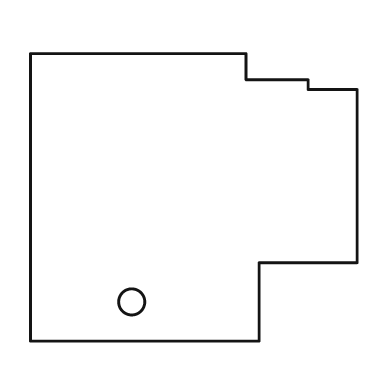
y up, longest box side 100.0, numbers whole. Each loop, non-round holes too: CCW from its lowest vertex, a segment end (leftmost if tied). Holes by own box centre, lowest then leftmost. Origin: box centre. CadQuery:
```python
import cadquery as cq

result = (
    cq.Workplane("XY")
    .moveTo(-50.0, -44.0)
    .lineTo(20.0, -44.0)
    .lineTo(20.0, -20.0)
    .lineTo(50.0, -20.0)
    .lineTo(50.0, 33.0)
    .lineTo(35.0, 33.0)
    .lineTo(35.0, 36.0)
    .lineTo(16.0, 36.0)
    .lineTo(16.0, 44.0)
    .lineTo(-50.0, 44.0)
    .close()
    .moveTo(-19.0, -32.0)
    .circle(4.0)
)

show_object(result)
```